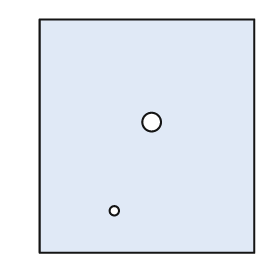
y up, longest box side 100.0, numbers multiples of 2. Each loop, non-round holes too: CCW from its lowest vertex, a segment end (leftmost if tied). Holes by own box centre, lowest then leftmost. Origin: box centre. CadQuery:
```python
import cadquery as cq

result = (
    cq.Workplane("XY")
    .moveTo(-46.0, -50.0)
    .lineTo(46.0, -50.0)
    .lineTo(46.0, 50.0)
    .lineTo(-46.0, 50.0)
    .close()
    .moveTo(-14.0, -32.0)
    .circle(2.0)
    .moveTo(2.0, 6.0)
    .circle(4.0)
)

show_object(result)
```